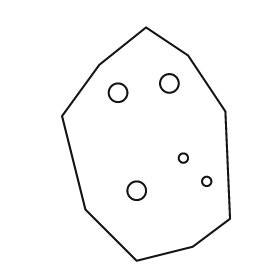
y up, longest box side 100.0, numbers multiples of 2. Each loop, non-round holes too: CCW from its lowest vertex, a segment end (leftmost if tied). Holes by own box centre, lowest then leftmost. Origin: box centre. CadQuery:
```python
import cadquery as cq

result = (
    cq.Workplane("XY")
    .moveTo(-4.0, -50.0)
    .lineTo(20.0, -44.0)
    .lineTo(36.0, -32.0)
    .lineTo(34.0, 14.0)
    .lineTo(18.0, 38.0)
    .lineTo(0.0, 50.0)
    .lineTo(-20.0, 34.0)
    .lineTo(-36.0, 12.0)
    .lineTo(-26.0, -28.0)
    .close()
    .moveTo(-4.0, -20.0)
    .circle(4.0)
    .moveTo(26.0, -16.0)
    .circle(2.0)
    .moveTo(16.0, -6.0)
    .circle(2.0)
    .moveTo(-12.0, 22.0)
    .circle(4.0)
    .moveTo(10.0, 26.0)
    .circle(4.0)
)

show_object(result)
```